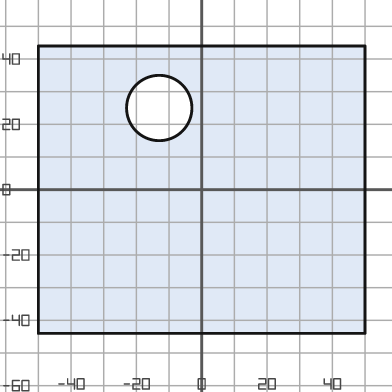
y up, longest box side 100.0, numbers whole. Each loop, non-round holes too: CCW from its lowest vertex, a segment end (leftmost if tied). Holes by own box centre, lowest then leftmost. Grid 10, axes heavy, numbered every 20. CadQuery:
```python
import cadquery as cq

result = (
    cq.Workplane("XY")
    .moveTo(-50.0, -44.0)
    .lineTo(50.0, -44.0)
    .lineTo(50.0, 44.0)
    .lineTo(-50.0, 44.0)
    .close()
    .moveTo(-13.0, 25.0)
    .circle(10.0)
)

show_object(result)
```